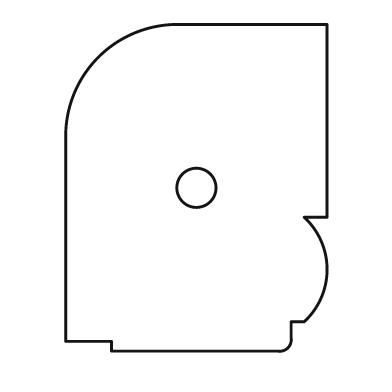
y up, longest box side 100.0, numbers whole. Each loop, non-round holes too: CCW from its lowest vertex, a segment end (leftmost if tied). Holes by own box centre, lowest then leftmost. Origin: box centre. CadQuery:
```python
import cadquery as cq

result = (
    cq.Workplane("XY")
    .moveTo(-26.0, -50.0)
    .lineTo(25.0, -50.0)
    .threePointArc((28.0, -49.0), (29.0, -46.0))
    .lineTo(29.0, -41.0)
    .lineTo(33.0, -41.0)
    .threePointArc((40.0, -25.0), (33.0, -9.0))
    .lineTo(40.0, -9.0)
    .lineTo(40.0, 50.0)
    .lineTo(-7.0, 50.0)
    .threePointArc((-30.0, 40.0), (-40.0, 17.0))
    .lineTo(-40.0, -47.0)
    .lineTo(-26.0, -47.0)
    .close()
    .moveTo(0.0, 0.0)
    .circle(6.0)
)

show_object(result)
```